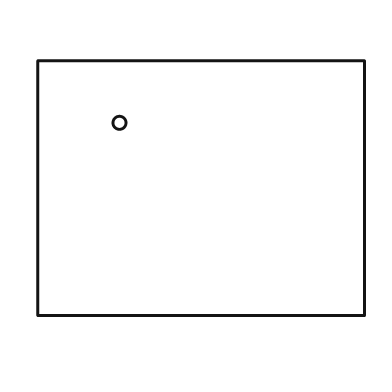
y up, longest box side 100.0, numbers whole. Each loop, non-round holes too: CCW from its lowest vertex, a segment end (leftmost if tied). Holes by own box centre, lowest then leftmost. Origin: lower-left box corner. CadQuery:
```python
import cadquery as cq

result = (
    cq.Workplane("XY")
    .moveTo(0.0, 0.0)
    .lineTo(100.0, 0.0)
    .lineTo(100.0, 78.0)
    .lineTo(0.0, 78.0)
    .close()
    .moveTo(25.0, 59.0)
    .circle(2.0)
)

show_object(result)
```